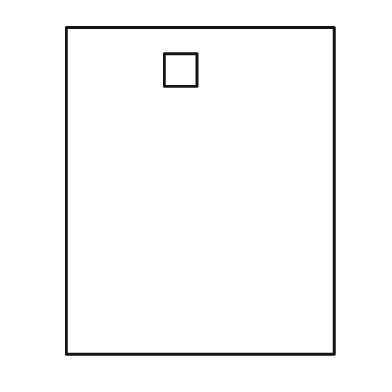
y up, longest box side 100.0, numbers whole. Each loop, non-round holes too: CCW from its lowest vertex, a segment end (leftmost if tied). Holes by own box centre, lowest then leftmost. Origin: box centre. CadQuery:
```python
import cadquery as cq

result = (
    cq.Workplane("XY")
    .moveTo(-41.0, -50.0)
    .lineTo(41.0, -50.0)
    .lineTo(41.0, 50.0)
    .lineTo(-41.0, 50.0)
    .close()
    .moveTo(-11.0, 32.0)
    .lineTo(-1.0, 32.0)
    .lineTo(-1.0, 42.0)
    .lineTo(-11.0, 42.0)
    .close()
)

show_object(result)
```